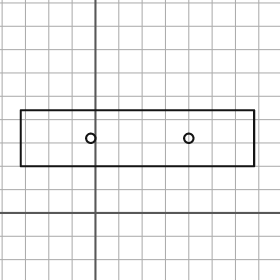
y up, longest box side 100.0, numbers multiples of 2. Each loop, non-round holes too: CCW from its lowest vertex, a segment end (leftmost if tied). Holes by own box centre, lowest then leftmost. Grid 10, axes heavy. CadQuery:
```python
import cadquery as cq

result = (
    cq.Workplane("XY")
    .moveTo(-32.0, 20.0)
    .lineTo(68.0, 20.0)
    .lineTo(68.0, 44.0)
    .lineTo(-32.0, 44.0)
    .close()
    .moveTo(-2.0, 32.0)
    .circle(2.0)
    .moveTo(40.0, 32.0)
    .circle(2.0)
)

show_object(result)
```